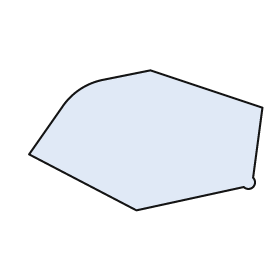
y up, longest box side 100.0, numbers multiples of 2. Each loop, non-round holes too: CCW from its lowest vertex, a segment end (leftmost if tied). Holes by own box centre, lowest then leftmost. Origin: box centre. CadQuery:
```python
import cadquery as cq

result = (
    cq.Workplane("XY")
    .moveTo(-4.0, -30.0)
    .lineTo(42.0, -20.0)
    .threePointArc((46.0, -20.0), (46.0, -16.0))
    .lineTo(50.0, 14.0)
    .lineTo(2.0, 30.0)
    .lineTo(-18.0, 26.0)
    .threePointArc((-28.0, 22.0), (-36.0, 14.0))
    .lineTo(-50.0, -6.0)
    .close()
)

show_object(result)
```